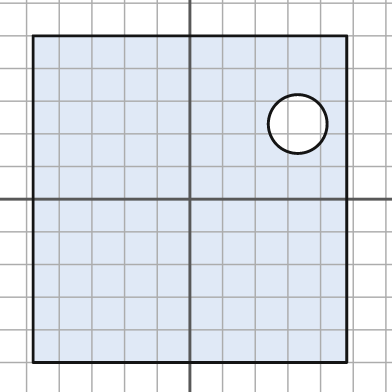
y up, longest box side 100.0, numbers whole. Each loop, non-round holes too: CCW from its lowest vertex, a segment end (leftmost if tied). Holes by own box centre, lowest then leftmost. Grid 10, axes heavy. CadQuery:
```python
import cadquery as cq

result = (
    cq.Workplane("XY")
    .moveTo(-48.0, -50.0)
    .lineTo(48.0, -50.0)
    .lineTo(48.0, 50.0)
    .lineTo(-48.0, 50.0)
    .close()
    .moveTo(33.0, 23.0)
    .circle(9.0)
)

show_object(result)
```